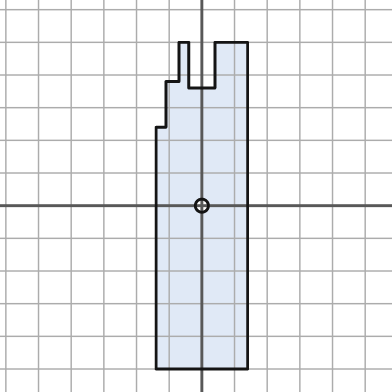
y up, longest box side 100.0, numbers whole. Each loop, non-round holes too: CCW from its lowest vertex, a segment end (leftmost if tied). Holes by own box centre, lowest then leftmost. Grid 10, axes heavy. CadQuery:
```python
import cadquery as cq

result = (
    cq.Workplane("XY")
    .moveTo(-14.0, -50.0)
    .lineTo(14.0, -50.0)
    .lineTo(14.0, 50.0)
    .lineTo(4.0, 50.0)
    .lineTo(4.0, 36.0)
    .lineTo(-4.0, 36.0)
    .lineTo(-4.0, 50.0)
    .lineTo(-7.0, 50.0)
    .lineTo(-7.0, 38.0)
    .lineTo(-11.0, 38.0)
    .lineTo(-11.0, 24.0)
    .lineTo(-14.0, 24.0)
    .close()
    .moveTo(0.0, 0.0)
    .circle(2.0)
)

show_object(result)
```